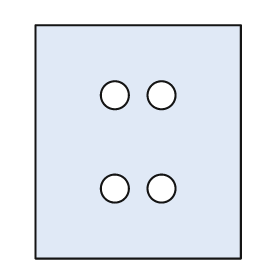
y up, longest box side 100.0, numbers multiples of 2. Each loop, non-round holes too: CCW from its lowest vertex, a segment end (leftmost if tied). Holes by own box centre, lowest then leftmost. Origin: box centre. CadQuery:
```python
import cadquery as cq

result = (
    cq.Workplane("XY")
    .moveTo(-44.0, -50.0)
    .lineTo(44.0, -50.0)
    .lineTo(44.0, 50.0)
    .lineTo(-44.0, 50.0)
    .close()
    .moveTo(-10.0, -20.0)
    .circle(6.0)
    .moveTo(10.0, -20.0)
    .circle(6.0)
    .moveTo(-10.0, 20.0)
    .circle(6.0)
    .moveTo(10.0, 20.0)
    .circle(6.0)
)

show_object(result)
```